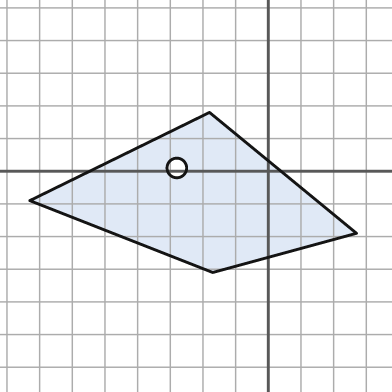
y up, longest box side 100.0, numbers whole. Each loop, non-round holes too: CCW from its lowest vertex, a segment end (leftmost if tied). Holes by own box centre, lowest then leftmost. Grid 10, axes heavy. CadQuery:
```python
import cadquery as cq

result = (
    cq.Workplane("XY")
    .moveTo(-17.0, -31.0)
    .lineTo(27.0, -19.0)
    .lineTo(-18.0, 18.0)
    .lineTo(-73.0, -9.0)
    .close()
    .moveTo(-28.0, 1.0)
    .circle(3.0)
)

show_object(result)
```